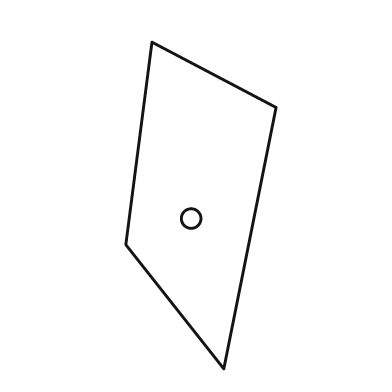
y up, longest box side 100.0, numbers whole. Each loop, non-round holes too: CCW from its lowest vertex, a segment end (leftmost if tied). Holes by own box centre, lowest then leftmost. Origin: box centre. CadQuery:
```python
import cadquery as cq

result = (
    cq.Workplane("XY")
    .moveTo(7.0, -50.0)
    .lineTo(23.0, 30.0)
    .lineTo(-15.0, 50.0)
    .lineTo(-23.0, -12.0)
    .close()
    .moveTo(-3.0, -4.0)
    .circle(3.0)
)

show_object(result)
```